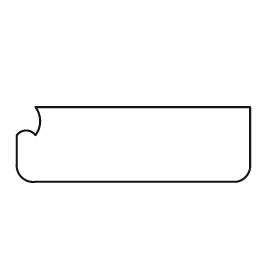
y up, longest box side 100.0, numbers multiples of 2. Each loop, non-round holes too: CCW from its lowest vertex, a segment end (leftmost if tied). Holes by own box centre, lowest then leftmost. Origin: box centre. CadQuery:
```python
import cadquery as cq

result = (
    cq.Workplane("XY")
    .moveTo(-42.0, -16.0)
    .lineTo(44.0, -16.0)
    .threePointArc((48.0, -14.0), (50.0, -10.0))
    .lineTo(50.0, 16.0)
    .lineTo(-42.0, 16.0)
    .threePointArc((-40.0, 10.0), (-42.0, 4.0))
    .threePointArc((-46.0, 6.0), (-50.0, 4.0))
    .lineTo(-50.0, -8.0)
    .threePointArc((-48.0, -14.0), (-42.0, -16.0))
    .close()
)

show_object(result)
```